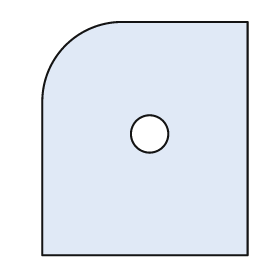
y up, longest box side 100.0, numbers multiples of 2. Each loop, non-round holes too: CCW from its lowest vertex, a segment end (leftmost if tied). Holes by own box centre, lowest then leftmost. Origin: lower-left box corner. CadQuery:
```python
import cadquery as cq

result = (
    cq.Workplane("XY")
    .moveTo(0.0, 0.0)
    .lineTo(88.0, 0.0)
    .lineTo(88.0, 100.0)
    .lineTo(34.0, 100.0)
    .threePointArc((10.0, 90.0), (0.0, 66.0))
    .close()
    .moveTo(46.0, 52.0)
    .circle(8.0)
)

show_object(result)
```